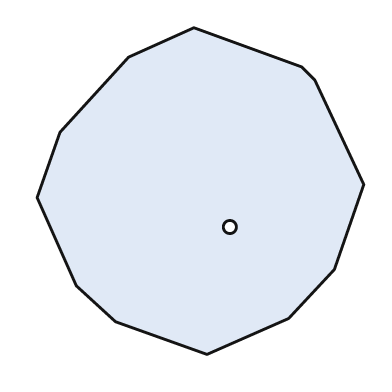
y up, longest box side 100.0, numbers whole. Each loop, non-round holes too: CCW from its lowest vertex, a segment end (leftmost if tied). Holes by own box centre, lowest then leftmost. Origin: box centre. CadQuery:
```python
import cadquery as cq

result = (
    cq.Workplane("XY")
    .moveTo(2.0, -50.0)
    .lineTo(27.0, -39.0)
    .lineTo(41.0, -24.0)
    .lineTo(50.0, 2.0)
    .lineTo(35.0, 34.0)
    .lineTo(31.0, 38.0)
    .lineTo(-2.0, 50.0)
    .lineTo(-22.0, 41.0)
    .lineTo(-43.0, 18.0)
    .lineTo(-50.0, -2.0)
    .lineTo(-38.0, -29.0)
    .lineTo(-26.0, -40.0)
    .close()
    .moveTo(9.0, -11.0)
    .circle(2.0)
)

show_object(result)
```